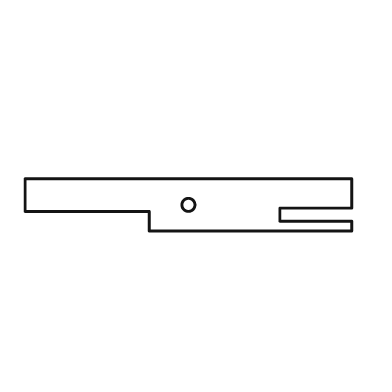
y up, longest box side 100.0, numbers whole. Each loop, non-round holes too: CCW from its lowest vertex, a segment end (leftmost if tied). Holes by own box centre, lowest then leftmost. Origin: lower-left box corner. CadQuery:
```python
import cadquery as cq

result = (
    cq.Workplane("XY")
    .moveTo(38.0, 0.0)
    .lineTo(100.0, 0.0)
    .lineTo(100.0, 3.0)
    .lineTo(78.0, 3.0)
    .lineTo(78.0, 7.0)
    .lineTo(100.0, 7.0)
    .lineTo(100.0, 16.0)
    .lineTo(0.0, 16.0)
    .lineTo(0.0, 6.0)
    .lineTo(38.0, 6.0)
    .close()
    .moveTo(50.0, 8.0)
    .circle(2.0)
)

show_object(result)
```